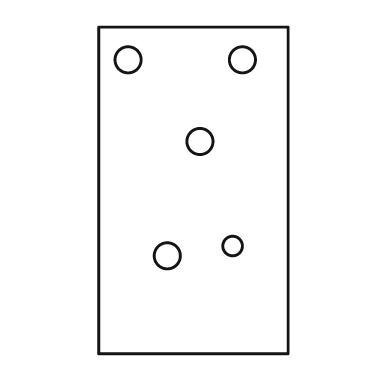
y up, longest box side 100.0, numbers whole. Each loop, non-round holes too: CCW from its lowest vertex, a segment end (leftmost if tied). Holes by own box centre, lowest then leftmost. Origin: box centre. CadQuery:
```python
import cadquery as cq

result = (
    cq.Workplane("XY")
    .moveTo(-29.0, -50.0)
    .lineTo(29.0, -50.0)
    .lineTo(29.0, 50.0)
    .lineTo(-29.0, 50.0)
    .close()
    .moveTo(-8.0, -20.0)
    .circle(4.0)
    .moveTo(12.0, -17.0)
    .circle(3.0)
    .moveTo(2.0, 15.0)
    .circle(4.0)
    .moveTo(-20.0, 40.0)
    .circle(4.0)
    .moveTo(15.0, 40.0)
    .circle(4.0)
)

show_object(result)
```